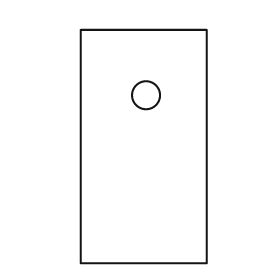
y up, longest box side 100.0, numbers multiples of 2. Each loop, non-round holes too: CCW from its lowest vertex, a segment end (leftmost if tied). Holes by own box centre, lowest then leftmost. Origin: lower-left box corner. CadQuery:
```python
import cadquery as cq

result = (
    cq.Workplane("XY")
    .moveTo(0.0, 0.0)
    .lineTo(54.0, 0.0)
    .lineTo(54.0, 100.0)
    .lineTo(0.0, 100.0)
    .close()
    .moveTo(28.0, 72.0)
    .circle(6.0)
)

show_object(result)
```